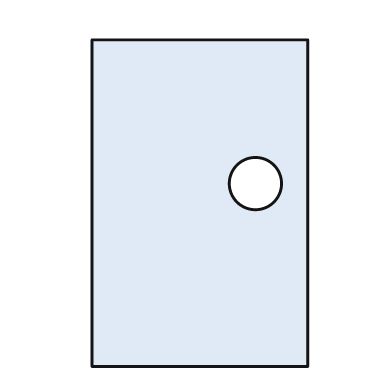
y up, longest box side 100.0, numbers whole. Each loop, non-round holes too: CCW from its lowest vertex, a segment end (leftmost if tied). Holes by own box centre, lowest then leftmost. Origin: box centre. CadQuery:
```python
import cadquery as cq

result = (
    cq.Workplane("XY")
    .moveTo(-33.0, -50.0)
    .lineTo(33.0, -50.0)
    .lineTo(33.0, 50.0)
    .lineTo(-33.0, 50.0)
    .close()
    .moveTo(17.0, 6.0)
    .circle(8.0)
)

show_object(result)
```